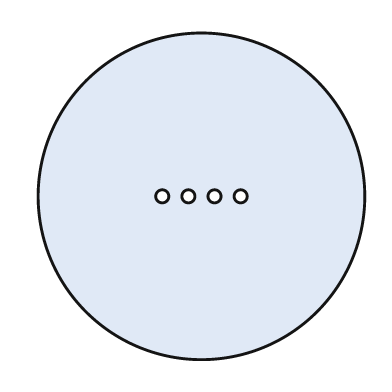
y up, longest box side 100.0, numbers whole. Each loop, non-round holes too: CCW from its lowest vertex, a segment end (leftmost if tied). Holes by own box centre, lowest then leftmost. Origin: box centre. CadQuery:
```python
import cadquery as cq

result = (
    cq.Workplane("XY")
    .moveTo(0.0, 0.0)
    .circle(50.0)
    .moveTo(-12.0, 0.0)
    .circle(2.0)
    .moveTo(-4.0, 0.0)
    .circle(2.0)
    .moveTo(4.0, 0.0)
    .circle(2.0)
    .moveTo(12.0, 0.0)
    .circle(2.0)
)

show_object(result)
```